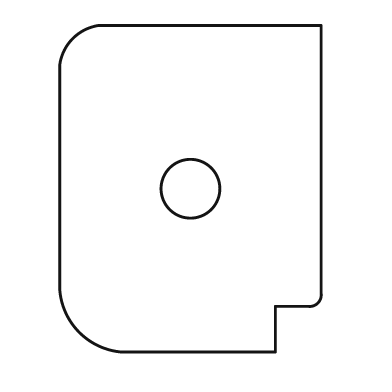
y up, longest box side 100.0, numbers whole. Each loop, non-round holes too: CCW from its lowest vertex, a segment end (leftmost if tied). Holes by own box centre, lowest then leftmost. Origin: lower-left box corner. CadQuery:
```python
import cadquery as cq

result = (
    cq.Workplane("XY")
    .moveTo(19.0, 0.0)
    .lineTo(66.0, 0.0)
    .lineTo(66.0, 14.0)
    .lineTo(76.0, 14.0)
    .threePointArc((79.0, 15.0), (80.0, 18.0))
    .lineTo(80.0, 100.0)
    .lineTo(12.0, 100.0)
    .threePointArc((4.0, 96.0), (0.0, 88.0))
    .lineTo(0.0, 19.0)
    .threePointArc((6.0, 6.0), (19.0, 0.0))
    .close()
    .moveTo(40.0, 50.0)
    .circle(9.0)
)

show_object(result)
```